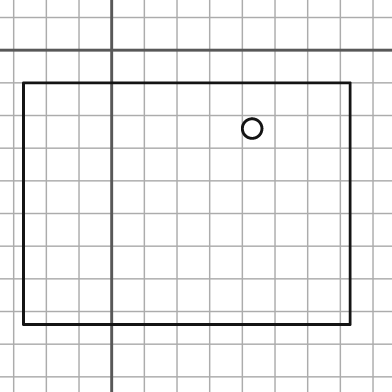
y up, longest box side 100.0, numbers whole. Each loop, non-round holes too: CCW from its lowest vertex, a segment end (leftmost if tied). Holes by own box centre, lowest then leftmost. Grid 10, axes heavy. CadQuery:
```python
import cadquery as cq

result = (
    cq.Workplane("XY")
    .moveTo(-27.0, -84.0)
    .lineTo(73.0, -84.0)
    .lineTo(73.0, -10.0)
    .lineTo(-27.0, -10.0)
    .close()
    .moveTo(43.0, -24.0)
    .circle(3.0)
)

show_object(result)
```